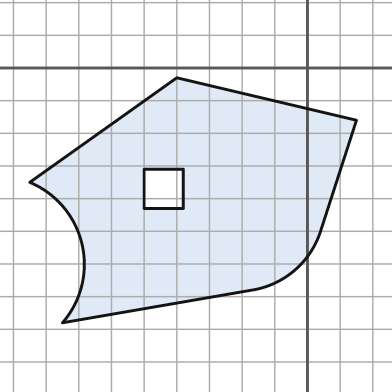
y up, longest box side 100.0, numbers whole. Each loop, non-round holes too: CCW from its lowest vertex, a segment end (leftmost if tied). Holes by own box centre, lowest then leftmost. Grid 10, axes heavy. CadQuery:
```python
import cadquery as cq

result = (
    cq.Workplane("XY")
    .moveTo(-75.0, -78.0)
    .lineTo(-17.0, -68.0)
    .threePointArc((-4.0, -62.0), (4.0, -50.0))
    .lineTo(15.0, -16.0)
    .lineTo(-40.0, -3.0)
    .lineTo(-85.0, -35.0)
    .threePointArc((-69.0, -54.0), (-75.0, -78.0))
    .close()
    .moveTo(-50.0, -43.0)
    .lineTo(-38.0, -43.0)
    .lineTo(-38.0, -31.0)
    .lineTo(-50.0, -31.0)
    .close()
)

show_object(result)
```